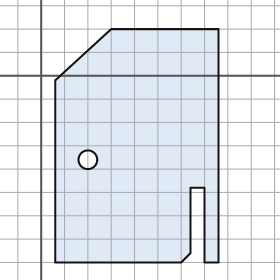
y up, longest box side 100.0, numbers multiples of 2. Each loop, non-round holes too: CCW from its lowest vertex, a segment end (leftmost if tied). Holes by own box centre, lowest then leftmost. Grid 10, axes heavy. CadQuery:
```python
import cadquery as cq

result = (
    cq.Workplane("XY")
    .moveTo(6.0, -80.0)
    .lineTo(60.0, -80.0)
    .lineTo(64.0, -76.0)
    .lineTo(64.0, -48.0)
    .lineTo(70.0, -48.0)
    .lineTo(70.0, -80.0)
    .lineTo(76.0, -80.0)
    .lineTo(76.0, 20.0)
    .lineTo(30.0, 20.0)
    .lineTo(6.0, -2.0)
    .close()
    .moveTo(20.0, -36.0)
    .circle(4.0)
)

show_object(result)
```